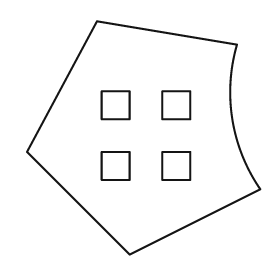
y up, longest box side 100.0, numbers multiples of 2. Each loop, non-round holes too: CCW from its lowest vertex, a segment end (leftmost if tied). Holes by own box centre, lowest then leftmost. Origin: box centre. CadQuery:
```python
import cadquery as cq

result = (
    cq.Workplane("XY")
    .moveTo(-6.0, -50.0)
    .lineTo(50.0, -22.0)
    .threePointArc((38.0, 8.0), (40.0, 40.0))
    .lineTo(-20.0, 50.0)
    .lineTo(-50.0, -6.0)
    .close()
    .moveTo(-18.0, -18.0)
    .lineTo(-6.0, -18.0)
    .lineTo(-6.0, -6.0)
    .lineTo(-18.0, -6.0)
    .close()
    .moveTo(8.0, -18.0)
    .lineTo(20.0, -18.0)
    .lineTo(20.0, -6.0)
    .lineTo(8.0, -6.0)
    .close()
    .moveTo(-18.0, 8.0)
    .lineTo(-6.0, 8.0)
    .lineTo(-6.0, 20.0)
    .lineTo(-18.0, 20.0)
    .close()
    .moveTo(8.0, 8.0)
    .lineTo(20.0, 8.0)
    .lineTo(20.0, 20.0)
    .lineTo(8.0, 20.0)
    .close()
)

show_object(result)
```